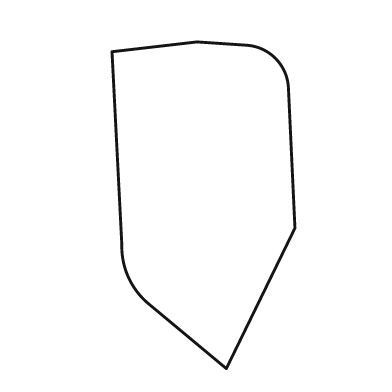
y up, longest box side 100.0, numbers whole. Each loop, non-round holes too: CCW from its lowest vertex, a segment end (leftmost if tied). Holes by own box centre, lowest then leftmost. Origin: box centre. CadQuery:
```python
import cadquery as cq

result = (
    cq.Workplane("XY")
    .moveTo(7.0, -50.0)
    .lineTo(28.0, -7.0)
    .lineTo(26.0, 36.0)
    .threePointArc((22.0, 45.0), (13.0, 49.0))
    .lineTo(-2.0, 50.0)
    .lineTo(-28.0, 47.0)
    .lineTo(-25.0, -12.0)
    .threePointArc((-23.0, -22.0), (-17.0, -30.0))
    .close()
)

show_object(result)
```